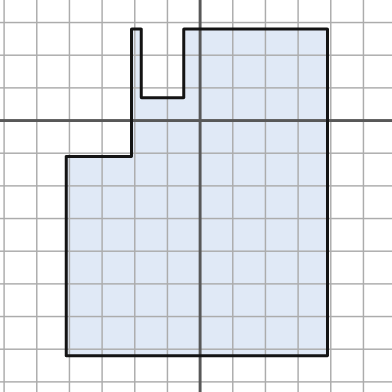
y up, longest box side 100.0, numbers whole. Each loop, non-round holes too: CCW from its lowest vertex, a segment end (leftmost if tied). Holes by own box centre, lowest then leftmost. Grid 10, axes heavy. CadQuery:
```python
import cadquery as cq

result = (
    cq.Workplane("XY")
    .moveTo(-41.0, -72.0)
    .lineTo(39.0, -72.0)
    .lineTo(39.0, 28.0)
    .lineTo(-5.0, 28.0)
    .lineTo(-5.0, 7.0)
    .lineTo(-18.0, 7.0)
    .lineTo(-18.0, 28.0)
    .lineTo(-21.0, 28.0)
    .lineTo(-21.0, -11.0)
    .lineTo(-41.0, -11.0)
    .close()
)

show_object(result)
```